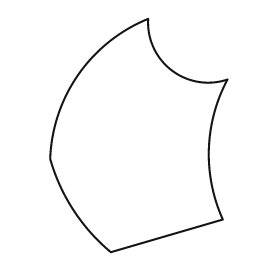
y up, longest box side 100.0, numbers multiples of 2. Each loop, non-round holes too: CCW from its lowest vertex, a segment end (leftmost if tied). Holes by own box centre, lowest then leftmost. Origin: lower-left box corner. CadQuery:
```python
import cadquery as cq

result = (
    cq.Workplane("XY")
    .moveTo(26.0, 0.0)
    .lineTo(74.0, 14.0)
    .threePointArc((68.0, 44.0), (76.0, 74.0))
    .threePointArc((52.0, 78.0), (42.0, 100.0))
    .threePointArc((12.0, 76.0), (0.0, 40.0))
    .threePointArc((10.0, 18.0), (26.0, 0.0))
    .close()
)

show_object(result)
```